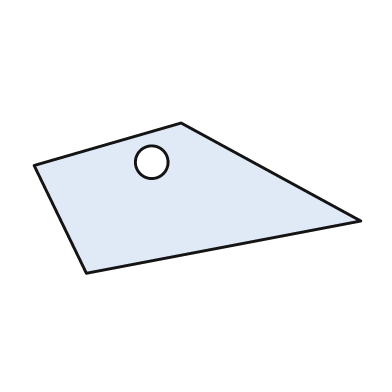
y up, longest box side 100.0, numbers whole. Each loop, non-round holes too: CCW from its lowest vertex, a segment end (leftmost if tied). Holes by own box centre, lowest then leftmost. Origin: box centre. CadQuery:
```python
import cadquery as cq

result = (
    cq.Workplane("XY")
    .moveTo(-34.0, -23.0)
    .lineTo(50.0, -7.0)
    .lineTo(-5.0, 23.0)
    .lineTo(-50.0, 10.0)
    .close()
    .moveTo(-14.0, 11.0)
    .circle(5.0)
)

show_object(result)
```